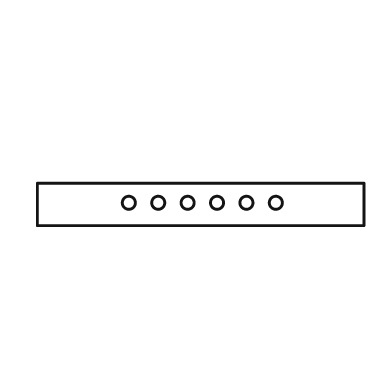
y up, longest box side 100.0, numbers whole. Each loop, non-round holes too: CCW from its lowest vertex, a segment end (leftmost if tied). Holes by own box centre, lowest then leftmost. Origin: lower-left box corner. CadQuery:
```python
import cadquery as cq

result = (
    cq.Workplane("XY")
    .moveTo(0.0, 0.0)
    .lineTo(100.0, 0.0)
    .lineTo(100.0, 13.0)
    .lineTo(0.0, 13.0)
    .close()
    .moveTo(28.0, 7.0)
    .circle(2.0)
    .moveTo(37.0, 7.0)
    .circle(2.0)
    .moveTo(46.0, 7.0)
    .circle(2.0)
    .moveTo(55.0, 7.0)
    .circle(2.0)
    .moveTo(64.0, 7.0)
    .circle(2.0)
    .moveTo(73.0, 7.0)
    .circle(2.0)
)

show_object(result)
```